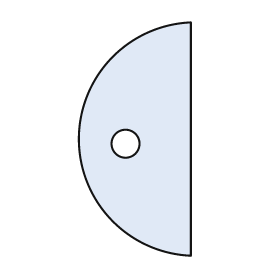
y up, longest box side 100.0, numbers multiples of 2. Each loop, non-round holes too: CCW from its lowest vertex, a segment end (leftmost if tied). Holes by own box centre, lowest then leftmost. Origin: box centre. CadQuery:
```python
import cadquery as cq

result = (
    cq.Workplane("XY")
    .moveTo(24.0, -50.0)
    .lineTo(24.0, 50.0)
    .threePointArc((-24.0, 0.0), (24.0, -50.0))
    .close()
    .moveTo(-4.0, -2.0)
    .circle(6.0)
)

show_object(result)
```